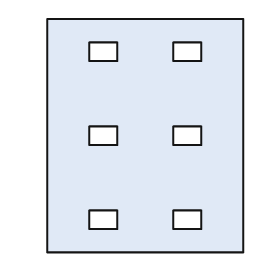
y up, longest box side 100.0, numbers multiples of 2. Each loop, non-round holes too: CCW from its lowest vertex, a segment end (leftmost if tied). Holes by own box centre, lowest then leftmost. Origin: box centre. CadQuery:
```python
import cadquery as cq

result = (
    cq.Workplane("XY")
    .moveTo(-42.0, -50.0)
    .lineTo(42.0, -50.0)
    .lineTo(42.0, 50.0)
    .lineTo(-42.0, 50.0)
    .close()
    .moveTo(-24.0, -40.0)
    .lineTo(-12.0, -40.0)
    .lineTo(-12.0, -32.0)
    .lineTo(-24.0, -32.0)
    .close()
    .moveTo(12.0, -40.0)
    .lineTo(24.0, -40.0)
    .lineTo(24.0, -32.0)
    .lineTo(12.0, -32.0)
    .close()
    .moveTo(-24.0, -4.0)
    .lineTo(-12.0, -4.0)
    .lineTo(-12.0, 4.0)
    .lineTo(-24.0, 4.0)
    .close()
    .moveTo(12.0, -4.0)
    .lineTo(24.0, -4.0)
    .lineTo(24.0, 4.0)
    .lineTo(12.0, 4.0)
    .close()
    .moveTo(-24.0, 32.0)
    .lineTo(-12.0, 32.0)
    .lineTo(-12.0, 40.0)
    .lineTo(-24.0, 40.0)
    .close()
    .moveTo(12.0, 32.0)
    .lineTo(24.0, 32.0)
    .lineTo(24.0, 40.0)
    .lineTo(12.0, 40.0)
    .close()
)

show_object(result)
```